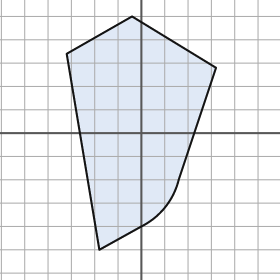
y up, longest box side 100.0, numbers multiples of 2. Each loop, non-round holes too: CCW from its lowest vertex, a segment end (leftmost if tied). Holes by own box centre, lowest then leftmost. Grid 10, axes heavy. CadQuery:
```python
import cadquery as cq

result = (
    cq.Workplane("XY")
    .moveTo(-18.0, -50.0)
    .lineTo(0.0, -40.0)
    .threePointArc((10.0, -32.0), (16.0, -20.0))
    .lineTo(32.0, 28.0)
    .lineTo(-4.0, 50.0)
    .lineTo(-32.0, 34.0)
    .close()
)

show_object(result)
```